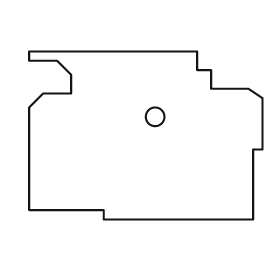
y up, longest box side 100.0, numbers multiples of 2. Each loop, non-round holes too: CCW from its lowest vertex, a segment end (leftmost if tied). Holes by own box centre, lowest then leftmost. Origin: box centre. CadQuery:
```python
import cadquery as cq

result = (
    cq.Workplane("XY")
    .moveTo(-18.0, -36.0)
    .lineTo(46.0, -36.0)
    .lineTo(46.0, -6.0)
    .lineTo(50.0, -6.0)
    .lineTo(50.0, 16.0)
    .lineTo(44.0, 20.0)
    .lineTo(28.0, 20.0)
    .lineTo(28.0, 28.0)
    .lineTo(22.0, 28.0)
    .lineTo(22.0, 36.0)
    .lineTo(-50.0, 36.0)
    .lineTo(-50.0, 32.0)
    .lineTo(-38.0, 32.0)
    .lineTo(-32.0, 26.0)
    .lineTo(-32.0, 18.0)
    .lineTo(-44.0, 18.0)
    .lineTo(-50.0, 12.0)
    .lineTo(-50.0, -32.0)
    .lineTo(-18.0, -32.0)
    .close()
    .moveTo(4.0, 8.0)
    .circle(4.0)
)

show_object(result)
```